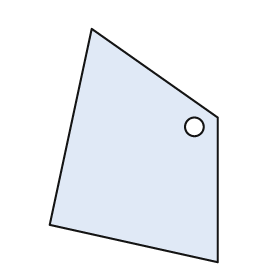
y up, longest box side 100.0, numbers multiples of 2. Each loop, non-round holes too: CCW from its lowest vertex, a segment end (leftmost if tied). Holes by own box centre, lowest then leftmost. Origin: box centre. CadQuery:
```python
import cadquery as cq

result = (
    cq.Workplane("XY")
    .moveTo(36.0, -50.0)
    .lineTo(36.0, 12.0)
    .lineTo(-18.0, 50.0)
    .lineTo(-36.0, -34.0)
    .close()
    .moveTo(26.0, 8.0)
    .circle(4.0)
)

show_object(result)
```